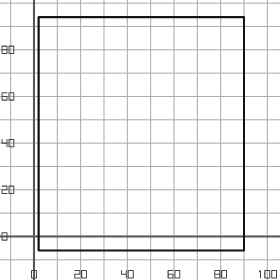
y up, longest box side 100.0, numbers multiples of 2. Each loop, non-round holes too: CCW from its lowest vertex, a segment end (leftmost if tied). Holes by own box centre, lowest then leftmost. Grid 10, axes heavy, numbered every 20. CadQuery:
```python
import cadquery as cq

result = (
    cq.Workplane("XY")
    .moveTo(2.0, -6.0)
    .lineTo(90.0, -6.0)
    .lineTo(90.0, 94.0)
    .lineTo(2.0, 94.0)
    .close()
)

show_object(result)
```